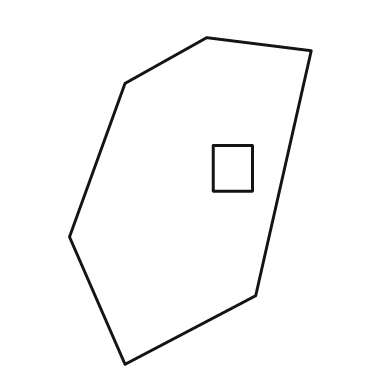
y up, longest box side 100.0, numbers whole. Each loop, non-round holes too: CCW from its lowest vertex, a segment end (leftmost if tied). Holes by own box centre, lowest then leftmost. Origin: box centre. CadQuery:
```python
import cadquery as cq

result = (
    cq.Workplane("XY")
    .moveTo(-20.0, -50.0)
    .lineTo(20.0, -29.0)
    .lineTo(37.0, 46.0)
    .lineTo(5.0, 50.0)
    .lineTo(-20.0, 36.0)
    .lineTo(-37.0, -11.0)
    .close()
    .moveTo(7.0, 3.0)
    .lineTo(19.0, 3.0)
    .lineTo(19.0, 17.0)
    .lineTo(7.0, 17.0)
    .close()
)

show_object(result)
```